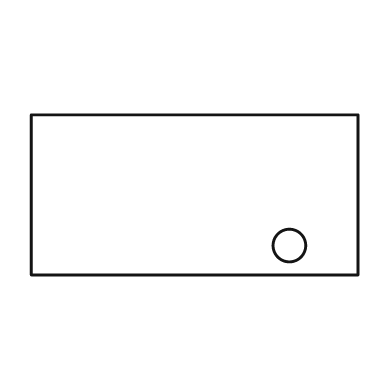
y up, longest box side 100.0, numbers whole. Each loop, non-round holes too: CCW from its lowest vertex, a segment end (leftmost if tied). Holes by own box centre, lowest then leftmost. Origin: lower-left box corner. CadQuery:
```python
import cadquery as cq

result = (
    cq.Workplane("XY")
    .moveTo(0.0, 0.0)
    .lineTo(100.0, 0.0)
    .lineTo(100.0, 49.0)
    .lineTo(0.0, 49.0)
    .close()
    .moveTo(79.0, 9.0)
    .circle(5.0)
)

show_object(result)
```